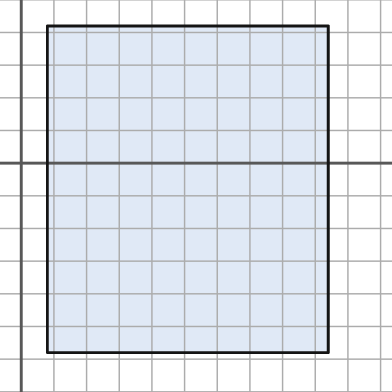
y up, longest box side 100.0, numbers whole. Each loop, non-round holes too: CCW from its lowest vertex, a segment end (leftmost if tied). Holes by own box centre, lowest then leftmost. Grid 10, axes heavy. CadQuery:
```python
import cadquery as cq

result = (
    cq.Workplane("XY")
    .moveTo(8.0, -58.0)
    .lineTo(94.0, -58.0)
    .lineTo(94.0, 42.0)
    .lineTo(8.0, 42.0)
    .close()
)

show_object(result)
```